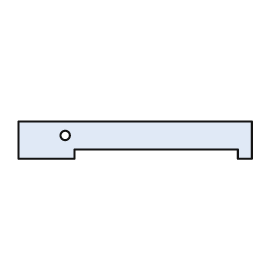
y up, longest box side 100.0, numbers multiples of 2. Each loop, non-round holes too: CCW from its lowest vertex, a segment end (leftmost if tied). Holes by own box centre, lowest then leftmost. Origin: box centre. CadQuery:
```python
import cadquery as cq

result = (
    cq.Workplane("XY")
    .moveTo(-50.0, -8.0)
    .lineTo(-26.0, -8.0)
    .lineTo(-26.0, -4.0)
    .lineTo(44.0, -4.0)
    .lineTo(44.0, -8.0)
    .lineTo(50.0, -8.0)
    .lineTo(50.0, 8.0)
    .lineTo(-50.0, 8.0)
    .close()
    .moveTo(-30.0, 2.0)
    .circle(2.0)
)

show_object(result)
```